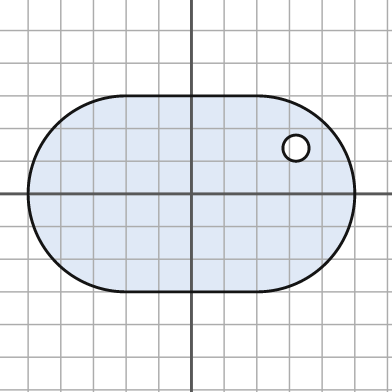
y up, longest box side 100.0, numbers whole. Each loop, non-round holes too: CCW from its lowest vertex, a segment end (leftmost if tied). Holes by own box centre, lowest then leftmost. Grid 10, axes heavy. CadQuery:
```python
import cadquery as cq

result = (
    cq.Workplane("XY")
    .moveTo(-20.0, -30.0)
    .lineTo(20.0, -30.0)
    .threePointArc((50.0, 0.0), (20.0, 30.0))
    .lineTo(-20.0, 30.0)
    .threePointArc((-50.0, 0.0), (-20.0, -30.0))
    .close()
    .moveTo(32.0, 14.0)
    .circle(4.0)
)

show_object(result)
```